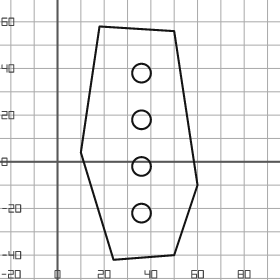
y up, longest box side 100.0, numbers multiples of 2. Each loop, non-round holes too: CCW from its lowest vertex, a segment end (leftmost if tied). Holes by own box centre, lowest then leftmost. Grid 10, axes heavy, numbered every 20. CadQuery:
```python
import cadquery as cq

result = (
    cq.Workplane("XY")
    .moveTo(24.0, -42.0)
    .lineTo(50.0, -40.0)
    .lineTo(60.0, -10.0)
    .lineTo(50.0, 56.0)
    .lineTo(18.0, 58.0)
    .lineTo(10.0, 4.0)
    .close()
    .moveTo(36.0, -22.0)
    .circle(4.0)
    .moveTo(36.0, -2.0)
    .circle(4.0)
    .moveTo(36.0, 18.0)
    .circle(4.0)
    .moveTo(36.0, 38.0)
    .circle(4.0)
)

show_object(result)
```